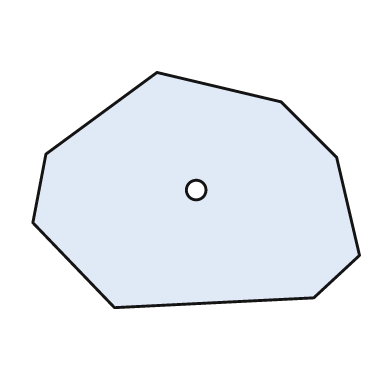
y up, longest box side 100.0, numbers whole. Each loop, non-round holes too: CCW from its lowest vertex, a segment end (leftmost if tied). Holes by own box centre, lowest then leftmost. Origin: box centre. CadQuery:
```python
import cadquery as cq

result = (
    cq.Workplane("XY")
    .moveTo(-25.0, -36.0)
    .lineTo(36.0, -33.0)
    .lineTo(50.0, -20.0)
    .lineTo(43.0, 10.0)
    .lineTo(26.0, 27.0)
    .lineTo(-12.0, 36.0)
    .lineTo(-46.0, 11.0)
    .lineTo(-50.0, -10.0)
    .close()
    .moveTo(0.0, 0.0)
    .circle(3.0)
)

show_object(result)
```